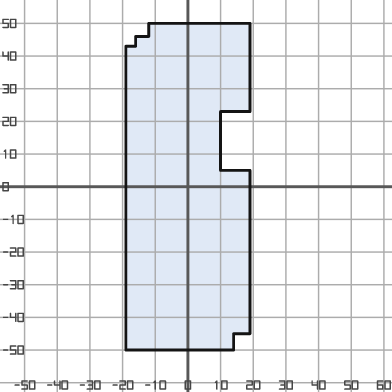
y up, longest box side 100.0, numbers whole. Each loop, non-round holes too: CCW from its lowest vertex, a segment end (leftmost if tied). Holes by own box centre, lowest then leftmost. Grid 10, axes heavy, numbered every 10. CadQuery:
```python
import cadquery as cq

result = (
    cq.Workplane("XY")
    .moveTo(-19.0, -50.0)
    .lineTo(14.0, -50.0)
    .lineTo(14.0, -45.0)
    .lineTo(19.0, -45.0)
    .lineTo(19.0, 5.0)
    .lineTo(10.0, 5.0)
    .lineTo(10.0, 23.0)
    .lineTo(19.0, 23.0)
    .lineTo(19.0, 50.0)
    .lineTo(-12.0, 50.0)
    .lineTo(-12.0, 46.0)
    .lineTo(-16.0, 46.0)
    .lineTo(-16.0, 43.0)
    .lineTo(-19.0, 43.0)
    .close()
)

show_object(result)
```